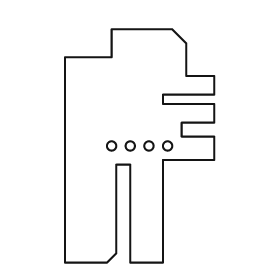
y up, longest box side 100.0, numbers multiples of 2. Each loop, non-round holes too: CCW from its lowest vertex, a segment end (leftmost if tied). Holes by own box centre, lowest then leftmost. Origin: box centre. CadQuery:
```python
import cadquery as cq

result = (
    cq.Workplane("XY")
    .moveTo(-32.0, -50.0)
    .lineTo(-14.0, -50.0)
    .lineTo(-10.0, -46.0)
    .lineTo(-10.0, -8.0)
    .lineTo(-4.0, -8.0)
    .lineTo(-4.0, -50.0)
    .lineTo(10.0, -50.0)
    .lineTo(10.0, -6.0)
    .lineTo(32.0, -6.0)
    .lineTo(32.0, 4.0)
    .lineTo(18.0, 4.0)
    .lineTo(18.0, 10.0)
    .lineTo(32.0, 10.0)
    .lineTo(32.0, 18.0)
    .lineTo(10.0, 18.0)
    .lineTo(10.0, 22.0)
    .lineTo(32.0, 22.0)
    .lineTo(32.0, 30.0)
    .lineTo(20.0, 30.0)
    .lineTo(20.0, 44.0)
    .lineTo(14.0, 50.0)
    .lineTo(-12.0, 50.0)
    .lineTo(-12.0, 38.0)
    .lineTo(-32.0, 38.0)
    .close()
    .moveTo(-12.0, 0.0)
    .circle(2.0)
    .moveTo(-4.0, 0.0)
    .circle(2.0)
    .moveTo(4.0, 0.0)
    .circle(2.0)
    .moveTo(12.0, 0.0)
    .circle(2.0)
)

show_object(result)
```